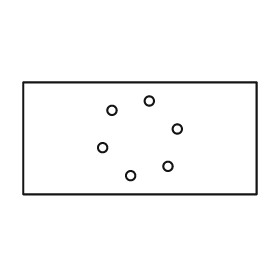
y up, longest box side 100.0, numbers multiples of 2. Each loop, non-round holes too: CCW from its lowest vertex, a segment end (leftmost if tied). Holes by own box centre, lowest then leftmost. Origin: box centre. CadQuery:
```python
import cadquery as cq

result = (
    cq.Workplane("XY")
    .moveTo(-50.0, -24.0)
    .lineTo(50.0, -24.0)
    .lineTo(50.0, 24.0)
    .lineTo(-50.0, 24.0)
    .close()
    .moveTo(-4.0, -16.0)
    .circle(2.0)
    .moveTo(12.0, -12.0)
    .circle(2.0)
    .moveTo(-16.0, -4.0)
    .circle(2.0)
    .moveTo(16.0, 4.0)
    .circle(2.0)
    .moveTo(-12.0, 12.0)
    .circle(2.0)
    .moveTo(4.0, 16.0)
    .circle(2.0)
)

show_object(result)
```